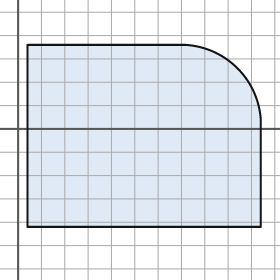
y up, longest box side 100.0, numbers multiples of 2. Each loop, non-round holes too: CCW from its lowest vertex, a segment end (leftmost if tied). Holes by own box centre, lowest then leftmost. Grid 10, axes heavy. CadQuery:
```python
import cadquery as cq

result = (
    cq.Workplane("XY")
    .moveTo(4.0, -42.0)
    .lineTo(104.0, -42.0)
    .lineTo(104.0, 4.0)
    .threePointArc((94.0, 26.0), (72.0, 36.0))
    .lineTo(4.0, 36.0)
    .close()
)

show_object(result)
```